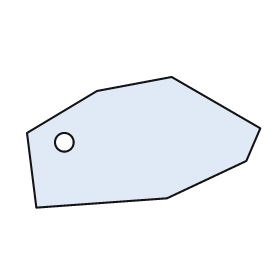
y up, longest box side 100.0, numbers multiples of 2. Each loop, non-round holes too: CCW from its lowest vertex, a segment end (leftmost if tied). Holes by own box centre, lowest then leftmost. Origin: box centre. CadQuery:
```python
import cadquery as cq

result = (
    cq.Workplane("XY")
    .moveTo(-46.0, -28.0)
    .lineTo(10.0, -24.0)
    .lineTo(44.0, -8.0)
    .lineTo(50.0, 6.0)
    .lineTo(12.0, 28.0)
    .lineTo(-20.0, 22.0)
    .lineTo(-50.0, 4.0)
    .close()
    .moveTo(-34.0, 0.0)
    .circle(4.0)
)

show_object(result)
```